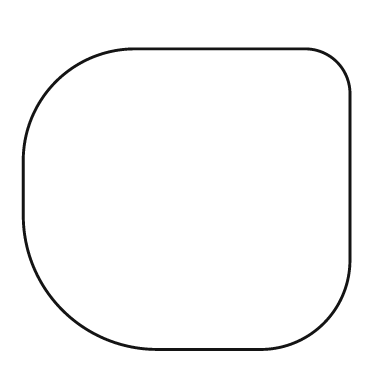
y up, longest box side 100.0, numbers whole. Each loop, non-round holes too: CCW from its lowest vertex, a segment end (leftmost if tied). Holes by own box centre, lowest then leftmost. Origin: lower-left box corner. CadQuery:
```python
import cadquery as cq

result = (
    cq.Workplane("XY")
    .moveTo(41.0, 0.0)
    .lineTo(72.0, 0.0)
    .threePointArc((92.0, 8.0), (100.0, 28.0))
    .lineTo(100.0, 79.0)
    .threePointArc((96.0, 88.0), (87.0, 92.0))
    .lineTo(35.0, 92.0)
    .threePointArc((10.0, 82.0), (0.0, 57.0))
    .lineTo(0.0, 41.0)
    .threePointArc((12.0, 12.0), (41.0, 0.0))
    .close()
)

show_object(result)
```